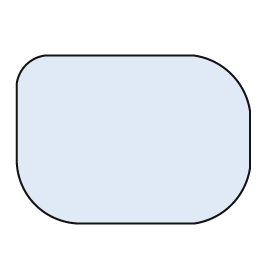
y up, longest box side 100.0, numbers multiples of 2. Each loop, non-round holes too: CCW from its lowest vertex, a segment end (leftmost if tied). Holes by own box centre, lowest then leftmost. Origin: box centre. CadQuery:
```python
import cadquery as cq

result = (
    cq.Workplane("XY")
    .moveTo(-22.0, -36.0)
    .lineTo(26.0, -36.0)
    .threePointArc((42.0, -28.0), (50.0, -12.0))
    .lineTo(50.0, 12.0)
    .threePointArc((42.0, 28.0), (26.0, 36.0))
    .lineTo(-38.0, 36.0)
    .threePointArc((-46.0, 32.0), (-50.0, 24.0))
    .lineTo(-50.0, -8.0)
    .threePointArc((-42.0, -28.0), (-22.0, -36.0))
    .close()
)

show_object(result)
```